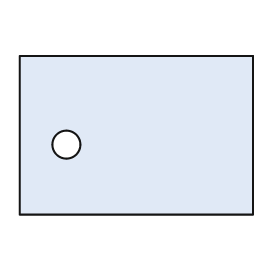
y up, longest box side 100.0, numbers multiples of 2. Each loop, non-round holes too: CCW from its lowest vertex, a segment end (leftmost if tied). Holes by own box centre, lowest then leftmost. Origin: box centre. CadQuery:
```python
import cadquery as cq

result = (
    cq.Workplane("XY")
    .moveTo(-50.0, -34.0)
    .lineTo(50.0, -34.0)
    .lineTo(50.0, 34.0)
    .lineTo(-50.0, 34.0)
    .close()
    .moveTo(-30.0, -4.0)
    .circle(6.0)
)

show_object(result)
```